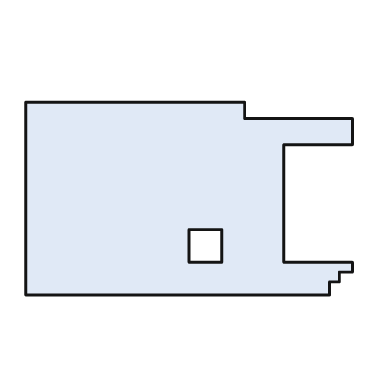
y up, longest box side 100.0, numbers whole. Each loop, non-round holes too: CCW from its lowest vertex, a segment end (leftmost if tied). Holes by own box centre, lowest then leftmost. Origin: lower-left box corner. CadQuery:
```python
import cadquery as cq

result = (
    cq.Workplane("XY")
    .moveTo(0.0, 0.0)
    .lineTo(93.0, 0.0)
    .lineTo(93.0, 4.0)
    .lineTo(96.0, 4.0)
    .lineTo(96.0, 7.0)
    .lineTo(100.0, 7.0)
    .lineTo(100.0, 10.0)
    .lineTo(79.0, 10.0)
    .lineTo(79.0, 46.0)
    .lineTo(100.0, 46.0)
    .lineTo(100.0, 54.0)
    .lineTo(67.0, 54.0)
    .lineTo(67.0, 59.0)
    .lineTo(0.0, 59.0)
    .close()
    .moveTo(50.0, 10.0)
    .lineTo(60.0, 10.0)
    .lineTo(60.0, 20.0)
    .lineTo(50.0, 20.0)
    .close()
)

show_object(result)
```